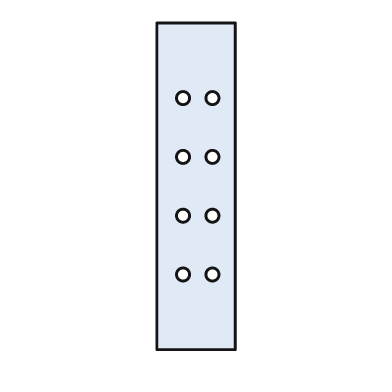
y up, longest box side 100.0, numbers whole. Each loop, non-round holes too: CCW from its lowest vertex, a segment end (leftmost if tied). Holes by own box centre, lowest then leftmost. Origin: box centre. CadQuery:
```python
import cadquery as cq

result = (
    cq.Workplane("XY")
    .moveTo(-12.0, -50.0)
    .lineTo(12.0, -50.0)
    .lineTo(12.0, 50.0)
    .lineTo(-12.0, 50.0)
    .close()
    .moveTo(-4.0, -27.0)
    .circle(2.0)
    .moveTo(5.0, -27.0)
    .circle(2.0)
    .moveTo(-4.0, -9.0)
    .circle(2.0)
    .moveTo(5.0, -9.0)
    .circle(2.0)
    .moveTo(-4.0, 9.0)
    .circle(2.0)
    .moveTo(5.0, 9.0)
    .circle(2.0)
    .moveTo(-4.0, 27.0)
    .circle(2.0)
    .moveTo(5.0, 27.0)
    .circle(2.0)
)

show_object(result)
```